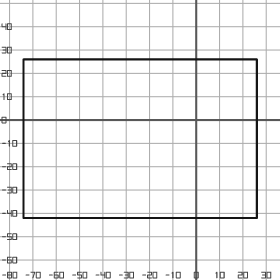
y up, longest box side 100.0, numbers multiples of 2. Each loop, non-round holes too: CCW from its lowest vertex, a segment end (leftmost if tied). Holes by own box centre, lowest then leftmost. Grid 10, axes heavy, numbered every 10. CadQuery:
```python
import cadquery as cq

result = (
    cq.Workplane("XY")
    .moveTo(-74.0, -42.0)
    .lineTo(26.0, -42.0)
    .lineTo(26.0, 26.0)
    .lineTo(-74.0, 26.0)
    .close()
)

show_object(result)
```